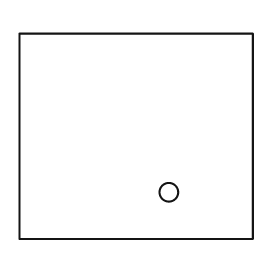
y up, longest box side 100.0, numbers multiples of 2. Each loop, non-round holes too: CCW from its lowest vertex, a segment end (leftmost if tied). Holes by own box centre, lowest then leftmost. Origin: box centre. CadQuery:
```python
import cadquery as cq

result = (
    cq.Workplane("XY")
    .moveTo(-50.0, -44.0)
    .lineTo(50.0, -44.0)
    .lineTo(50.0, 44.0)
    .lineTo(-50.0, 44.0)
    .close()
    .moveTo(14.0, -24.0)
    .circle(4.0)
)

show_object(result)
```